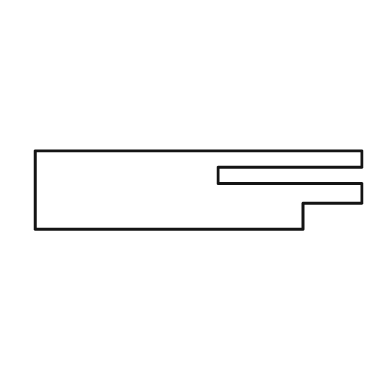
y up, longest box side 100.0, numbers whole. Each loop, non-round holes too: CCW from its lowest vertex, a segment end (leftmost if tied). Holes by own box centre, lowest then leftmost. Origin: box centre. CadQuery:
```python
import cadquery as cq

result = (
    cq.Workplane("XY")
    .moveTo(-50.0, -12.0)
    .lineTo(32.0, -12.0)
    .lineTo(32.0, -4.0)
    .lineTo(50.0, -4.0)
    .lineTo(50.0, 2.0)
    .lineTo(6.0, 2.0)
    .lineTo(6.0, 7.0)
    .lineTo(50.0, 7.0)
    .lineTo(50.0, 12.0)
    .lineTo(-50.0, 12.0)
    .close()
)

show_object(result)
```